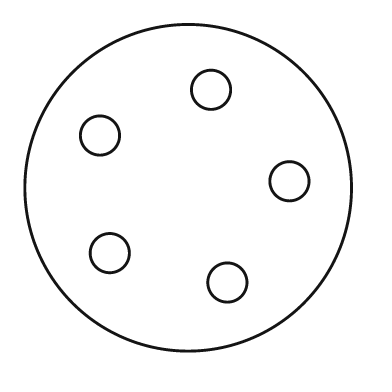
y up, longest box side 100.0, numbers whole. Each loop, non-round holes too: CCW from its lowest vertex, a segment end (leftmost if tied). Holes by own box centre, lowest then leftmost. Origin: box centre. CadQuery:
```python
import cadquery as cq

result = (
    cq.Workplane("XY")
    .moveTo(0.0, 0.0)
    .circle(50.0)
    .moveTo(12.0, -29.0)
    .circle(6.0)
    .moveTo(-24.0, -20.0)
    .circle(6.0)
    .moveTo(31.0, 2.0)
    .circle(6.0)
    .moveTo(-27.0, 16.0)
    .circle(6.0)
    .moveTo(7.0, 30.0)
    .circle(6.0)
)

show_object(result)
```